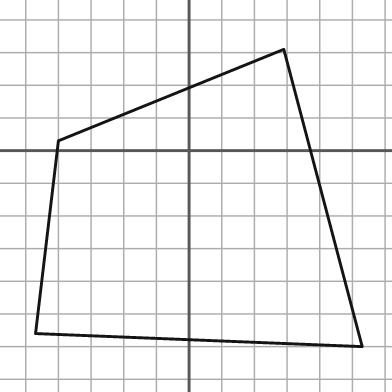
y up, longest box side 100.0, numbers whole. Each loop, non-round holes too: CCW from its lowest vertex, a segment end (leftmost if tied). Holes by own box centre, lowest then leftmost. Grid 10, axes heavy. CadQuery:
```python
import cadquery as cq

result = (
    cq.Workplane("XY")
    .moveTo(53.0, -60.0)
    .lineTo(29.0, 31.0)
    .lineTo(-40.0, 3.0)
    .lineTo(-47.0, -56.0)
    .close()
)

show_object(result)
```